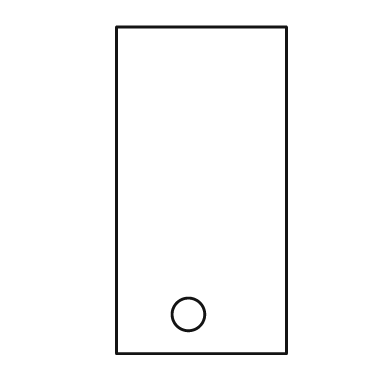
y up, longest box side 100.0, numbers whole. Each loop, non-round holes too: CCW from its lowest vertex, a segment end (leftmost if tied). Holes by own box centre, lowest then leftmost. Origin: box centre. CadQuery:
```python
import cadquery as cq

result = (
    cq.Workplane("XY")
    .moveTo(-26.0, -50.0)
    .lineTo(26.0, -50.0)
    .lineTo(26.0, 50.0)
    .lineTo(-26.0, 50.0)
    .close()
    .moveTo(-4.0, -38.0)
    .circle(5.0)
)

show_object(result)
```